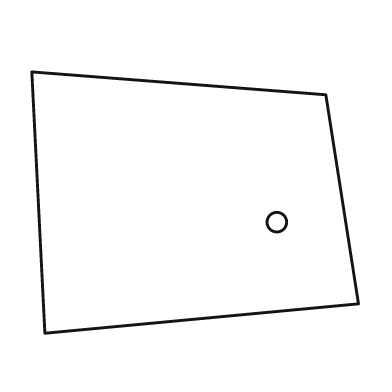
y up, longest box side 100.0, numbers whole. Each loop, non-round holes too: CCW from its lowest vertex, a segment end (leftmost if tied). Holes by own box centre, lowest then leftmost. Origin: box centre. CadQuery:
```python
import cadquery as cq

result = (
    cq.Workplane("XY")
    .moveTo(-46.0, -40.0)
    .lineTo(50.0, -31.0)
    .lineTo(40.0, 33.0)
    .lineTo(-50.0, 40.0)
    .close()
    .moveTo(25.0, -6.0)
    .circle(3.0)
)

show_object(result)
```